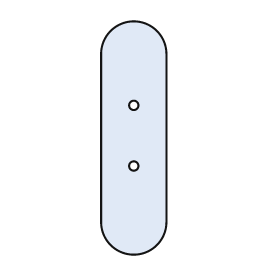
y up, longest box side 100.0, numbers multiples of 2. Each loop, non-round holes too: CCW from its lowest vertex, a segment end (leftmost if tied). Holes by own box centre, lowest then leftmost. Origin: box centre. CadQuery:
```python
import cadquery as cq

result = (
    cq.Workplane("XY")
    .moveTo(-14.0, -36.0)
    .threePointArc((0.0, -50.0), (14.0, -36.0))
    .lineTo(14.0, 36.0)
    .threePointArc((0.0, 50.0), (-14.0, 36.0))
    .close()
    .moveTo(0.0, -12.0)
    .circle(2.0)
    .moveTo(0.0, 14.0)
    .circle(2.0)
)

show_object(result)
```